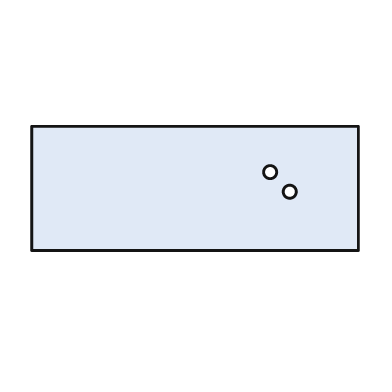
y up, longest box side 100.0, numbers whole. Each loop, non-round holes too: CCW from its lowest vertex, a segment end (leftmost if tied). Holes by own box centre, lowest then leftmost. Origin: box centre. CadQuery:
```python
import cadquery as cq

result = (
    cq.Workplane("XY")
    .moveTo(-50.0, -19.0)
    .lineTo(50.0, -19.0)
    .lineTo(50.0, 19.0)
    .lineTo(-50.0, 19.0)
    .close()
    .moveTo(29.0, -1.0)
    .circle(2.0)
    .moveTo(23.0, 5.0)
    .circle(2.0)
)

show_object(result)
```